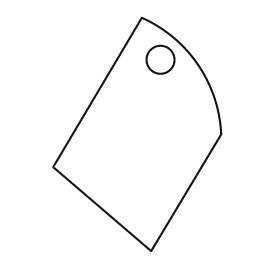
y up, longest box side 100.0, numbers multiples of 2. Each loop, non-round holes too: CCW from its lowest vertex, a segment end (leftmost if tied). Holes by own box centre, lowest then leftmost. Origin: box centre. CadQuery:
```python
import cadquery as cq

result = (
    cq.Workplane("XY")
    .moveTo(6.0, -50.0)
    .lineTo(36.0, 0.0)
    .threePointArc((26.0, 30.0), (2.0, 50.0))
    .lineTo(-36.0, -14.0)
    .close()
    .moveTo(10.0, 32.0)
    .circle(6.0)
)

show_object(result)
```